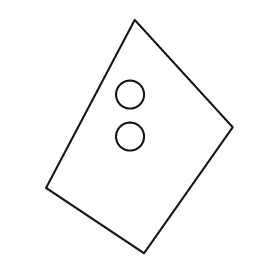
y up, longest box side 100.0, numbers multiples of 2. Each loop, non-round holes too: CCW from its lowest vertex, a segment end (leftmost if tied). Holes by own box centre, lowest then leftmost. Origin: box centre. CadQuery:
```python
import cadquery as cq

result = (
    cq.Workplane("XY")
    .moveTo(2.0, -50.0)
    .lineTo(40.0, 4.0)
    .lineTo(-2.0, 50.0)
    .lineTo(-40.0, -22.0)
    .close()
    .moveTo(-4.0, 0.0)
    .circle(6.0)
    .moveTo(-4.0, 18.0)
    .circle(6.0)
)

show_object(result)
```